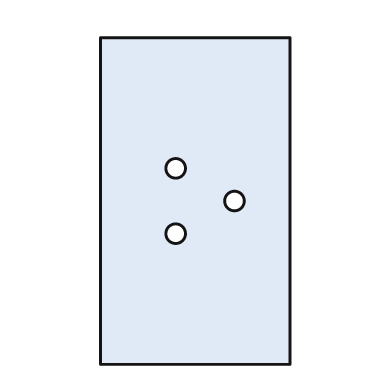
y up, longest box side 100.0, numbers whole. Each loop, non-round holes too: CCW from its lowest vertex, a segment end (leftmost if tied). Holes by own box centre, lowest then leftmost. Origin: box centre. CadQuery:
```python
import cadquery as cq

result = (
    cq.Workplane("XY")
    .moveTo(-29.0, -50.0)
    .lineTo(29.0, -50.0)
    .lineTo(29.0, 50.0)
    .lineTo(-29.0, 50.0)
    .close()
    .moveTo(-6.0, -10.0)
    .circle(3.0)
    .moveTo(12.0, 0.0)
    .circle(3.0)
    .moveTo(-6.0, 10.0)
    .circle(3.0)
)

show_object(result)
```